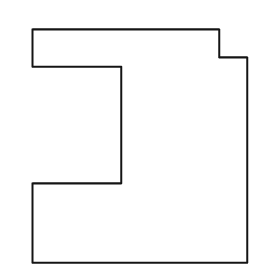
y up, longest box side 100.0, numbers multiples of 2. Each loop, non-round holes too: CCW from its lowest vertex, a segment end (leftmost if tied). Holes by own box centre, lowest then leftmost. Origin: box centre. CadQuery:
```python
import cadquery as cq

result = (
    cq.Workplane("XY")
    .moveTo(-46.0, -50.0)
    .lineTo(46.0, -50.0)
    .lineTo(46.0, 38.0)
    .lineTo(34.0, 38.0)
    .lineTo(34.0, 50.0)
    .lineTo(-46.0, 50.0)
    .lineTo(-46.0, 34.0)
    .lineTo(-8.0, 34.0)
    .lineTo(-8.0, -16.0)
    .lineTo(-46.0, -16.0)
    .close()
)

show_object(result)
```